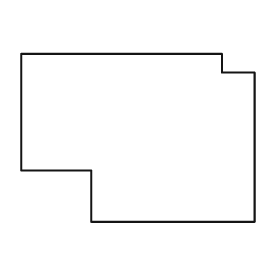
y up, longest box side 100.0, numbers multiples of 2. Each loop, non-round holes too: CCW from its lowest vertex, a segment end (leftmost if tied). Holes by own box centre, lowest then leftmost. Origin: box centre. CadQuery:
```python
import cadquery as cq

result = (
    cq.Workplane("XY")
    .moveTo(-20.0, -36.0)
    .lineTo(50.0, -36.0)
    .lineTo(50.0, 28.0)
    .lineTo(36.0, 28.0)
    .lineTo(36.0, 36.0)
    .lineTo(-50.0, 36.0)
    .lineTo(-50.0, -14.0)
    .lineTo(-20.0, -14.0)
    .close()
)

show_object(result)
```